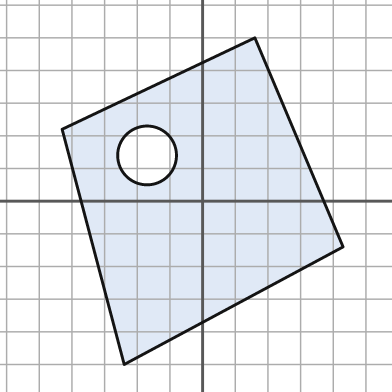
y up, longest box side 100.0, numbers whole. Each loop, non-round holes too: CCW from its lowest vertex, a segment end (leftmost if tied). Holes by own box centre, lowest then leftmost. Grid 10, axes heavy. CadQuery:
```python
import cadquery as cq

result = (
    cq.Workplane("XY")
    .moveTo(-24.0, -50.0)
    .lineTo(43.0, -14.0)
    .lineTo(16.0, 50.0)
    .lineTo(-43.0, 22.0)
    .close()
    .moveTo(-17.0, 14.0)
    .circle(9.0)
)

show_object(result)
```